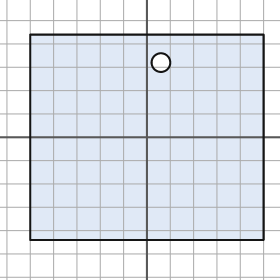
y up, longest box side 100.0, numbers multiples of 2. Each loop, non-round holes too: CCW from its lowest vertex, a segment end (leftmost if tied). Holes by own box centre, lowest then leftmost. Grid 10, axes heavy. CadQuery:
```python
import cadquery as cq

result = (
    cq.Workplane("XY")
    .moveTo(-50.0, -44.0)
    .lineTo(50.0, -44.0)
    .lineTo(50.0, 44.0)
    .lineTo(-50.0, 44.0)
    .close()
    .moveTo(6.0, 32.0)
    .circle(4.0)
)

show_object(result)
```